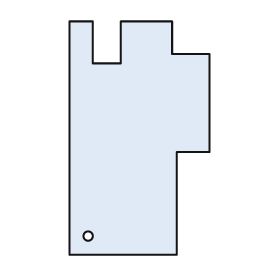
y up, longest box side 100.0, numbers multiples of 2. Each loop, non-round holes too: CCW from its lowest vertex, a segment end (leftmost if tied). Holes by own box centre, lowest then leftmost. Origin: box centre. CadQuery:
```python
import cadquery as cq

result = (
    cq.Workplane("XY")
    .moveTo(-30.0, -50.0)
    .lineTo(16.0, -50.0)
    .lineTo(16.0, -6.0)
    .lineTo(30.0, -6.0)
    .lineTo(30.0, 36.0)
    .lineTo(14.0, 36.0)
    .lineTo(14.0, 50.0)
    .lineTo(-8.0, 50.0)
    .lineTo(-8.0, 32.0)
    .lineTo(-20.0, 32.0)
    .lineTo(-20.0, 50.0)
    .lineTo(-30.0, 50.0)
    .close()
    .moveTo(-22.0, -42.0)
    .circle(2.0)
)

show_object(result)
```